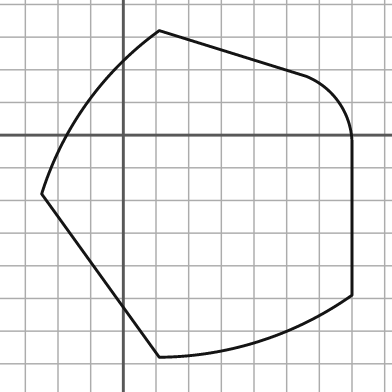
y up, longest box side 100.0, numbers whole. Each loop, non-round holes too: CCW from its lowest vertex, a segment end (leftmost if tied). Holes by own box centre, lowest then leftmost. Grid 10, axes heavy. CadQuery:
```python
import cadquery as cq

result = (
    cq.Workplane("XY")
    .moveTo(11.0, -68.0)
    .threePointArc((42.0, -63.0), (70.0, -49.0))
    .lineTo(70.0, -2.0)
    .threePointArc((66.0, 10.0), (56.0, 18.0))
    .lineTo(11.0, 32.0)
    .threePointArc((-11.0, 10.0), (-25.0, -18.0))
    .close()
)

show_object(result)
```